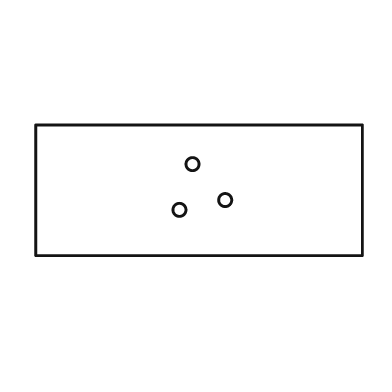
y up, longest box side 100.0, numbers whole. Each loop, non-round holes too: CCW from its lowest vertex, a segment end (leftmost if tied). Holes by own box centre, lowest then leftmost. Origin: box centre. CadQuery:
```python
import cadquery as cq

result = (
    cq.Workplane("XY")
    .moveTo(-50.0, -20.0)
    .lineTo(50.0, -20.0)
    .lineTo(50.0, 20.0)
    .lineTo(-50.0, 20.0)
    .close()
    .moveTo(-6.0, -6.0)
    .circle(2.0)
    .moveTo(8.0, -3.0)
    .circle(2.0)
    .moveTo(-2.0, 8.0)
    .circle(2.0)
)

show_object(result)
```